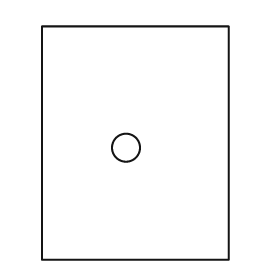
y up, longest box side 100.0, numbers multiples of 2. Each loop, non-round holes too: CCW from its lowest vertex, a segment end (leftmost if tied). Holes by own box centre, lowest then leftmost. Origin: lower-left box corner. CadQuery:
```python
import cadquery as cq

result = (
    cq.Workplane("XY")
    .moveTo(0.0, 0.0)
    .lineTo(80.0, 0.0)
    .lineTo(80.0, 100.0)
    .lineTo(0.0, 100.0)
    .close()
    .moveTo(36.0, 48.0)
    .circle(6.0)
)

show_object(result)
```